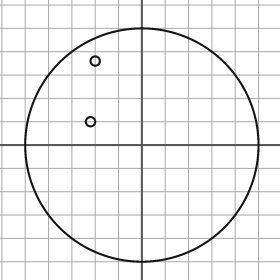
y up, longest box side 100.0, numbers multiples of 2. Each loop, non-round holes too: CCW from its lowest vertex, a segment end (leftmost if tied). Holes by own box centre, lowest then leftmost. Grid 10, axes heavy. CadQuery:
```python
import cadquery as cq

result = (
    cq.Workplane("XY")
    .moveTo(0.0, 0.0)
    .circle(50.0)
    .moveTo(-22.0, 10.0)
    .circle(2.0)
    .moveTo(-20.0, 36.0)
    .circle(2.0)
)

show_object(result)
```